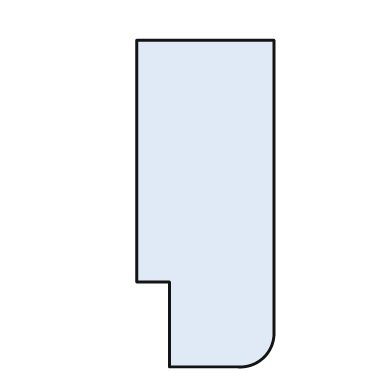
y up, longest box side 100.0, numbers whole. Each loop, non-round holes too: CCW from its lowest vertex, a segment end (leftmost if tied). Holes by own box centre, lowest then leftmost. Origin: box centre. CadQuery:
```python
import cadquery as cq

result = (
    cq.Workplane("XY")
    .moveTo(-11.0, -50.0)
    .lineTo(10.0, -50.0)
    .threePointArc((18.0, -47.0), (21.0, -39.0))
    .lineTo(21.0, 50.0)
    .lineTo(-21.0, 50.0)
    .lineTo(-21.0, -24.0)
    .lineTo(-11.0, -24.0)
    .close()
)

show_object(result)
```